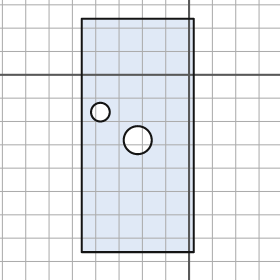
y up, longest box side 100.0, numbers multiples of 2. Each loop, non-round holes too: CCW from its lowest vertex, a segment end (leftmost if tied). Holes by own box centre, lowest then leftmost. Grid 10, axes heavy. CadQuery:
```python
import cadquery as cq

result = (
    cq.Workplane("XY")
    .moveTo(-46.0, -76.0)
    .lineTo(2.0, -76.0)
    .lineTo(2.0, 24.0)
    .lineTo(-46.0, 24.0)
    .close()
    .moveTo(-22.0, -28.0)
    .circle(6.0)
    .moveTo(-38.0, -16.0)
    .circle(4.0)
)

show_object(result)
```